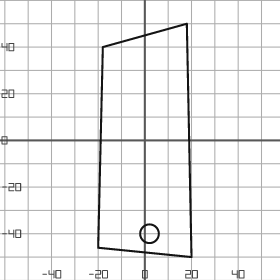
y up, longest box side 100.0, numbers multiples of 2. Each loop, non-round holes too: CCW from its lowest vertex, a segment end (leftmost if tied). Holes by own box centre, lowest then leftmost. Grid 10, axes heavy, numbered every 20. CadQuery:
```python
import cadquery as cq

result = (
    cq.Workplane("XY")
    .moveTo(20.0, -50.0)
    .lineTo(18.0, 50.0)
    .lineTo(-18.0, 40.0)
    .lineTo(-20.0, -46.0)
    .close()
    .moveTo(2.0, -40.0)
    .circle(4.0)
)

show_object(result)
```